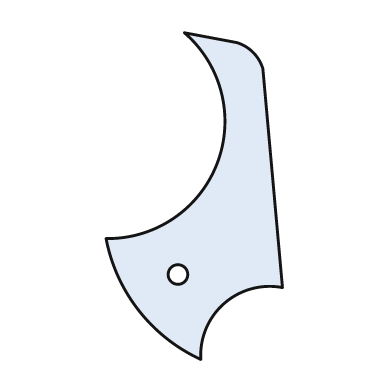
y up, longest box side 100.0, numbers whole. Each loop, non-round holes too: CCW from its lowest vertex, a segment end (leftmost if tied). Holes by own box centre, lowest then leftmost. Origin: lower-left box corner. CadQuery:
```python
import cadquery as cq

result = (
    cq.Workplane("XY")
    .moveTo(29.0, 0.0)
    .threePointArc((36.0, 17.0), (54.0, 22.0))
    .lineTo(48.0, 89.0)
    .threePointArc((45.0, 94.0), (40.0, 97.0))
    .lineTo(24.0, 100.0)
    .threePointArc((34.0, 60.0), (0.0, 37.0))
    .threePointArc((10.0, 15.0), (29.0, 0.0))
    .close()
    .moveTo(22.0, 26.0)
    .circle(3.0)
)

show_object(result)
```